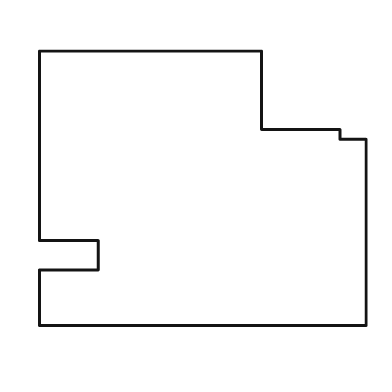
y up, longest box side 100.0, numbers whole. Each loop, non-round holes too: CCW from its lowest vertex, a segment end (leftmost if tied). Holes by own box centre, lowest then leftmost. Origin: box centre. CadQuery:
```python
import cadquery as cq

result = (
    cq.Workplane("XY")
    .moveTo(-50.0, -42.0)
    .lineTo(50.0, -42.0)
    .lineTo(50.0, 15.0)
    .lineTo(42.0, 15.0)
    .lineTo(42.0, 18.0)
    .lineTo(18.0, 18.0)
    .lineTo(18.0, 42.0)
    .lineTo(-50.0, 42.0)
    .lineTo(-50.0, -16.0)
    .lineTo(-32.0, -16.0)
    .lineTo(-32.0, -25.0)
    .lineTo(-50.0, -25.0)
    .close()
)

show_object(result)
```